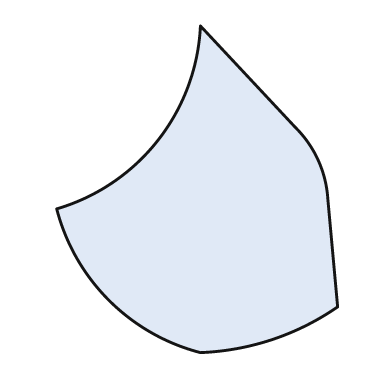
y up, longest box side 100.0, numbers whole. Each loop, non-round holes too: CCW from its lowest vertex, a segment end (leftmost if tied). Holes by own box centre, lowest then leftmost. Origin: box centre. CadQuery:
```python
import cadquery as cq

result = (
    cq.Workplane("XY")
    .moveTo(1.0, -50.0)
    .threePointArc((23.0, -46.0), (43.0, -36.0))
    .lineTo(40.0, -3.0)
    .threePointArc((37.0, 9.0), (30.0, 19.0))
    .lineTo(1.0, 50.0)
    .threePointArc((-12.0, 15.0), (-43.0, -6.0))
    .threePointArc((-27.0, -34.0), (1.0, -50.0))
    .close()
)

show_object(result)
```